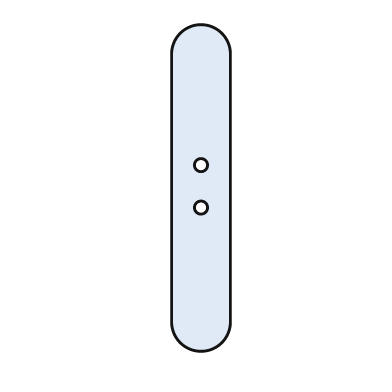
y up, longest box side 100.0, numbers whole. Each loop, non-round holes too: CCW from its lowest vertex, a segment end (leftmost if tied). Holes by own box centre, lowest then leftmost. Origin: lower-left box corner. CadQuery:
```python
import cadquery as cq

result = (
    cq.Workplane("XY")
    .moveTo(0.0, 9.0)
    .threePointArc((9.0, 0.0), (18.0, 9.0))
    .lineTo(18.0, 91.0)
    .threePointArc((9.0, 100.0), (0.0, 91.0))
    .close()
    .moveTo(9.0, 44.0)
    .circle(2.0)
    .moveTo(9.0, 57.0)
    .circle(2.0)
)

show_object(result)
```